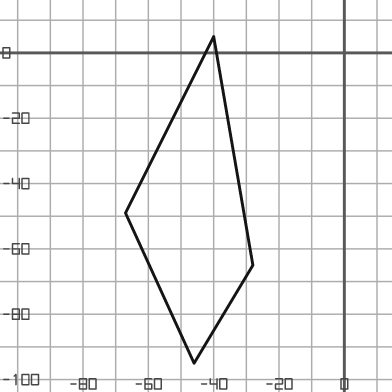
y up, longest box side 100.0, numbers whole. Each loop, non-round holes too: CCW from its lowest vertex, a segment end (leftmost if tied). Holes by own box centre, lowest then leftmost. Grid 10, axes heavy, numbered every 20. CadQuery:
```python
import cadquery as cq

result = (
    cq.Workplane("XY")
    .moveTo(-46.0, -95.0)
    .lineTo(-28.0, -65.0)
    .lineTo(-40.0, 5.0)
    .lineTo(-67.0, -49.0)
    .close()
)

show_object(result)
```